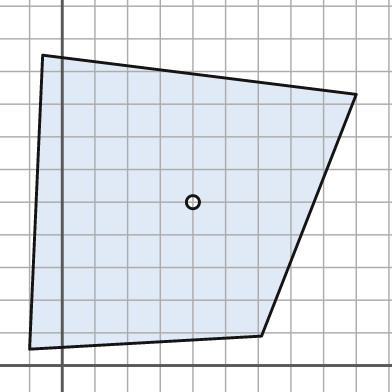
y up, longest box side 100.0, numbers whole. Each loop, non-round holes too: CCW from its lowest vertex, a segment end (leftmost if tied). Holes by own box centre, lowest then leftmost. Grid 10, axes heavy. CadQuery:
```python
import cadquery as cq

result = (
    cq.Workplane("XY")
    .moveTo(-10.0, 5.0)
    .lineTo(61.0, 9.0)
    .lineTo(90.0, 83.0)
    .lineTo(-6.0, 95.0)
    .close()
    .moveTo(40.0, 50.0)
    .circle(2.0)
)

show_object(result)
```